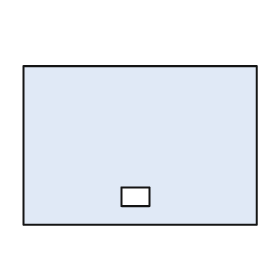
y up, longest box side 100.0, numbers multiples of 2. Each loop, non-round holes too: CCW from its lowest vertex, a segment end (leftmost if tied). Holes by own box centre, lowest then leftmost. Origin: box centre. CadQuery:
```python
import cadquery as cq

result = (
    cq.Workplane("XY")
    .moveTo(-50.0, -34.0)
    .lineTo(50.0, -34.0)
    .lineTo(50.0, 34.0)
    .lineTo(-50.0, 34.0)
    .close()
    .moveTo(-8.0, -26.0)
    .lineTo(4.0, -26.0)
    .lineTo(4.0, -18.0)
    .lineTo(-8.0, -18.0)
    .close()
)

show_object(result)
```